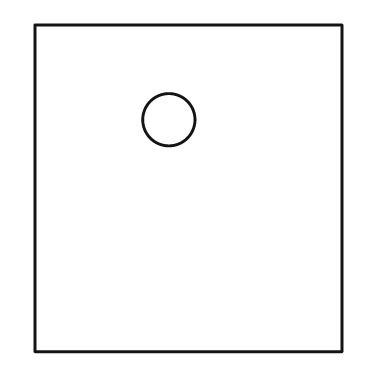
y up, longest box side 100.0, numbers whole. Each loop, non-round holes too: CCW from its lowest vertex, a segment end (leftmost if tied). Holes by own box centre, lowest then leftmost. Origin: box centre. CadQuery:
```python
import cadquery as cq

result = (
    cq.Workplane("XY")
    .moveTo(-47.0, -50.0)
    .lineTo(47.0, -50.0)
    .lineTo(47.0, 50.0)
    .lineTo(-47.0, 50.0)
    .close()
    .moveTo(-6.0, 21.0)
    .circle(8.0)
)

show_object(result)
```